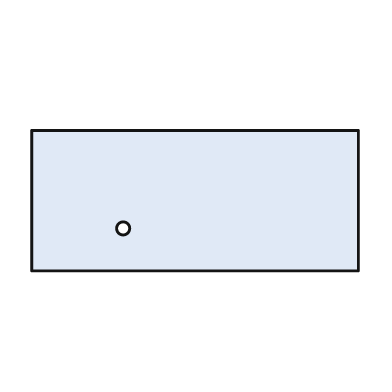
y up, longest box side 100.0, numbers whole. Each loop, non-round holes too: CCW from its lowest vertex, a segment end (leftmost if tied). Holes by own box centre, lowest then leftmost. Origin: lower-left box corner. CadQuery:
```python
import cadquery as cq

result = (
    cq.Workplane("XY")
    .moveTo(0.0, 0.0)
    .lineTo(100.0, 0.0)
    .lineTo(100.0, 43.0)
    .lineTo(0.0, 43.0)
    .close()
    .moveTo(28.0, 13.0)
    .circle(2.0)
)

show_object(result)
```